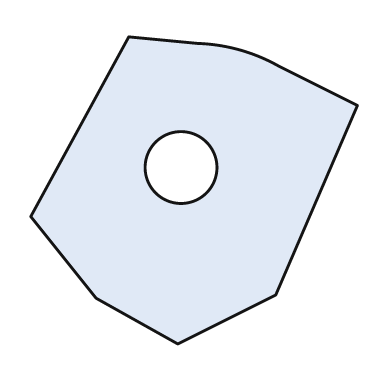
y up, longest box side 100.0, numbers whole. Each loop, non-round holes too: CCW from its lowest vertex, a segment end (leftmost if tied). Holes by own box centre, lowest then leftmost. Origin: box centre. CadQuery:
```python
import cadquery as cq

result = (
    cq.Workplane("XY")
    .moveTo(-5.0, -47.0)
    .lineTo(25.0, -32.0)
    .lineTo(50.0, 26.0)
    .lineTo(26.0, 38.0)
    .threePointArc((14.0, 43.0), (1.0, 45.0))
    .lineTo(-20.0, 47.0)
    .lineTo(-50.0, -8.0)
    .lineTo(-30.0, -33.0)
    .close()
    .moveTo(-4.0, 7.0)
    .circle(11.0)
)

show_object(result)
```